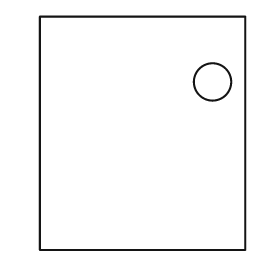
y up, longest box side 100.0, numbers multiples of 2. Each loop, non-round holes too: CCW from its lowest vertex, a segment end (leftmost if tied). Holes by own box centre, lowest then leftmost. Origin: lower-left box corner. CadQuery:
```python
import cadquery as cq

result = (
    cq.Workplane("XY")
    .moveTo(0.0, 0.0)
    .lineTo(88.0, 0.0)
    .lineTo(88.0, 100.0)
    .lineTo(0.0, 100.0)
    .close()
    .moveTo(74.0, 72.0)
    .circle(8.0)
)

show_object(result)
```